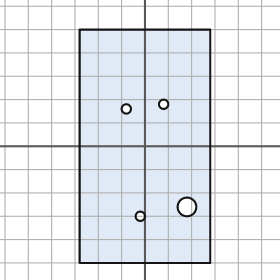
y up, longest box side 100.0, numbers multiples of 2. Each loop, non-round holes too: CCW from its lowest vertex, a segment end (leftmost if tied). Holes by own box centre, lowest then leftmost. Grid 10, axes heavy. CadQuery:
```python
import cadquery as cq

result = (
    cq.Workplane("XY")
    .moveTo(-28.0, -50.0)
    .lineTo(28.0, -50.0)
    .lineTo(28.0, 50.0)
    .lineTo(-28.0, 50.0)
    .close()
    .moveTo(-2.0, -30.0)
    .circle(2.0)
    .moveTo(18.0, -26.0)
    .circle(4.0)
    .moveTo(-8.0, 16.0)
    .circle(2.0)
    .moveTo(8.0, 18.0)
    .circle(2.0)
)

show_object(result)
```